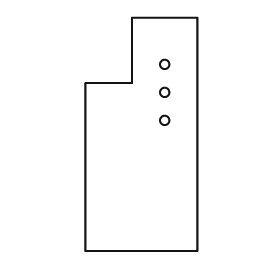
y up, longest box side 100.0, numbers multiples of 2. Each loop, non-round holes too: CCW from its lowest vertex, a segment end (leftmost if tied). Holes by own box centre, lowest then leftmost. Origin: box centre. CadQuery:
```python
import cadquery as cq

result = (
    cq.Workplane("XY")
    .moveTo(-24.0, -50.0)
    .lineTo(24.0, -50.0)
    .lineTo(24.0, 50.0)
    .lineTo(-4.0, 50.0)
    .lineTo(-4.0, 22.0)
    .lineTo(-24.0, 22.0)
    .close()
    .moveTo(10.0, 6.0)
    .circle(2.0)
    .moveTo(10.0, 18.0)
    .circle(2.0)
    .moveTo(10.0, 30.0)
    .circle(2.0)
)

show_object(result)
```